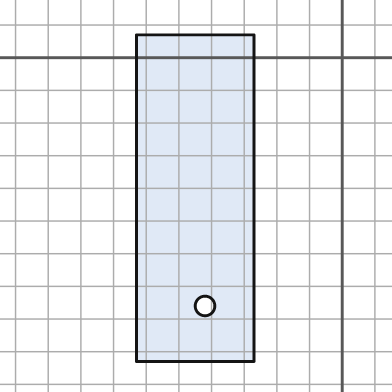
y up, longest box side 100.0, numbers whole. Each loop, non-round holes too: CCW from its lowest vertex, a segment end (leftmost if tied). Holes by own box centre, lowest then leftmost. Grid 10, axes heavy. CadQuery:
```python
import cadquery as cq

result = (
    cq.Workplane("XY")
    .moveTo(-63.0, -93.0)
    .lineTo(-27.0, -93.0)
    .lineTo(-27.0, 7.0)
    .lineTo(-63.0, 7.0)
    .close()
    .moveTo(-42.0, -76.0)
    .circle(3.0)
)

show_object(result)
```